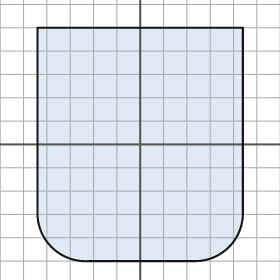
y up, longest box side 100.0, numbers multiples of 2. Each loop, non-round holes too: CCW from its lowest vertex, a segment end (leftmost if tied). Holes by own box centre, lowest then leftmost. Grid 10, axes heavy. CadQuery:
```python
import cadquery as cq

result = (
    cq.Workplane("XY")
    .moveTo(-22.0, -50.0)
    .lineTo(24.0, -50.0)
    .threePointArc((38.0, -44.0), (44.0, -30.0))
    .lineTo(44.0, 50.0)
    .lineTo(-44.0, 50.0)
    .lineTo(-44.0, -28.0)
    .threePointArc((-38.0, -44.0), (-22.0, -50.0))
    .close()
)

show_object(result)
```